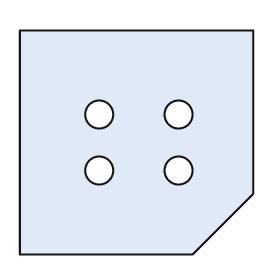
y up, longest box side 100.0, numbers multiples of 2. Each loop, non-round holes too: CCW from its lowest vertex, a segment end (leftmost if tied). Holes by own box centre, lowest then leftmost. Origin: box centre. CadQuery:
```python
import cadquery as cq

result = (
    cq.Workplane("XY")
    .moveTo(-50.0, -48.0)
    .lineTo(24.0, -48.0)
    .lineTo(50.0, -22.0)
    .lineTo(50.0, 48.0)
    .lineTo(-50.0, 48.0)
    .close()
    .moveTo(-16.0, -12.0)
    .circle(6.0)
    .moveTo(18.0, -12.0)
    .circle(6.0)
    .moveTo(-16.0, 12.0)
    .circle(6.0)
    .moveTo(18.0, 12.0)
    .circle(6.0)
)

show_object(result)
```